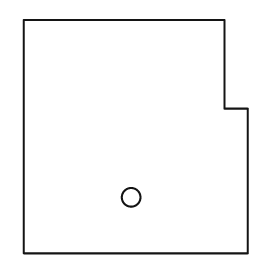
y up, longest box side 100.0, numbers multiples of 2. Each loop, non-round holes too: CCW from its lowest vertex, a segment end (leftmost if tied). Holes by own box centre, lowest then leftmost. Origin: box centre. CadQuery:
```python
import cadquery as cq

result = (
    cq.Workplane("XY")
    .moveTo(-48.0, -50.0)
    .lineTo(48.0, -50.0)
    .lineTo(48.0, 12.0)
    .lineTo(38.0, 12.0)
    .lineTo(38.0, 50.0)
    .lineTo(-48.0, 50.0)
    .close()
    .moveTo(-2.0, -26.0)
    .circle(4.0)
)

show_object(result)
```